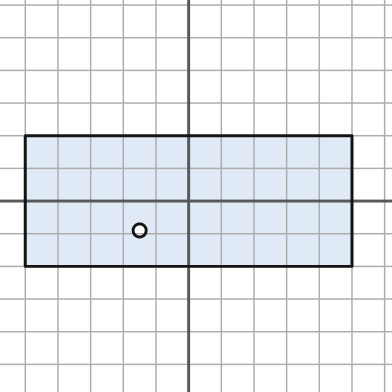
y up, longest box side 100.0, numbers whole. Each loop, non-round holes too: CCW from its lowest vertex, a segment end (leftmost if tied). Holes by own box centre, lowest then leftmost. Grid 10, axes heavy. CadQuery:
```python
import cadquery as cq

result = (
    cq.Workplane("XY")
    .moveTo(-50.0, -20.0)
    .lineTo(50.0, -20.0)
    .lineTo(50.0, 20.0)
    .lineTo(-50.0, 20.0)
    .close()
    .moveTo(-15.0, -9.0)
    .circle(2.0)
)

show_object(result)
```